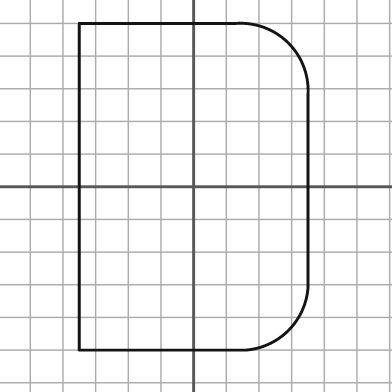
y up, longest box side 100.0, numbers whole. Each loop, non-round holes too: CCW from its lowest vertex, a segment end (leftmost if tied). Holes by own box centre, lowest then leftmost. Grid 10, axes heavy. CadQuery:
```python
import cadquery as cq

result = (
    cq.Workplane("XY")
    .moveTo(-35.0, -50.0)
    .lineTo(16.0, -50.0)
    .threePointArc((29.0, -44.0), (35.0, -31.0))
    .lineTo(35.0, 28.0)
    .threePointArc((29.0, 44.0), (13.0, 50.0))
    .lineTo(-35.0, 50.0)
    .close()
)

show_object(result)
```